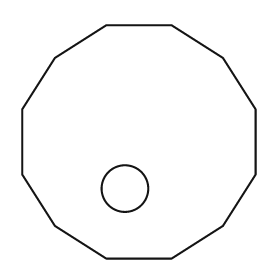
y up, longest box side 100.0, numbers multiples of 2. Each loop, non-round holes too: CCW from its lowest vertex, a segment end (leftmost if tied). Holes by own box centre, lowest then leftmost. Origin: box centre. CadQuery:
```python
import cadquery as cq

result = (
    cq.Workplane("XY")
    .moveTo(-14.0, -50.0)
    .lineTo(14.0, -50.0)
    .lineTo(36.0, -36.0)
    .lineTo(50.0, -14.0)
    .lineTo(50.0, 14.0)
    .lineTo(36.0, 36.0)
    .lineTo(14.0, 50.0)
    .lineTo(-14.0, 50.0)
    .lineTo(-36.0, 36.0)
    .lineTo(-50.0, 14.0)
    .lineTo(-50.0, -14.0)
    .lineTo(-36.0, -36.0)
    .close()
    .moveTo(-6.0, -20.0)
    .circle(10.0)
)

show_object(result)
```